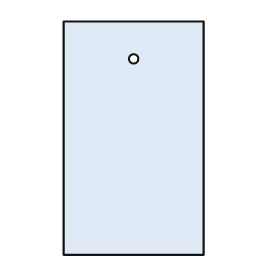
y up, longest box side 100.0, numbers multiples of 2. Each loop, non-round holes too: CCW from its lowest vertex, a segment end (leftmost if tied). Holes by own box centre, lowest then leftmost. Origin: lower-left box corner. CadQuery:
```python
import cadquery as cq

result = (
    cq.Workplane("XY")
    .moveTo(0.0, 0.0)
    .lineTo(60.0, 0.0)
    .lineTo(60.0, 100.0)
    .lineTo(0.0, 100.0)
    .close()
    .moveTo(30.0, 84.0)
    .circle(2.0)
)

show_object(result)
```